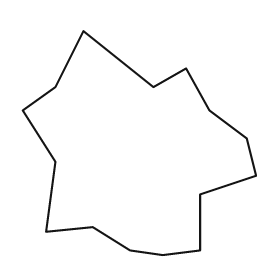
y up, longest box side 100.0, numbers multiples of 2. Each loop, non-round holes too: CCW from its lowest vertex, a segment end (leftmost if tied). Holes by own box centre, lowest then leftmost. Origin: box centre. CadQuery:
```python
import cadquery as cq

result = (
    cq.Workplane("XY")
    .moveTo(10.0, -48.0)
    .lineTo(26.0, -46.0)
    .lineTo(26.0, -22.0)
    .lineTo(50.0, -14.0)
    .lineTo(46.0, 2.0)
    .lineTo(30.0, 14.0)
    .lineTo(20.0, 32.0)
    .lineTo(6.0, 24.0)
    .lineTo(-24.0, 48.0)
    .lineTo(-36.0, 24.0)
    .lineTo(-50.0, 14.0)
    .lineTo(-36.0, -8.0)
    .lineTo(-40.0, -38.0)
    .lineTo(-20.0, -36.0)
    .lineTo(-4.0, -46.0)
    .close()
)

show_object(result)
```